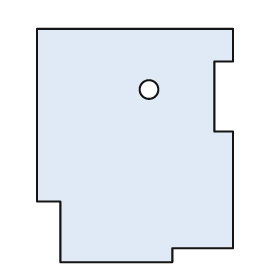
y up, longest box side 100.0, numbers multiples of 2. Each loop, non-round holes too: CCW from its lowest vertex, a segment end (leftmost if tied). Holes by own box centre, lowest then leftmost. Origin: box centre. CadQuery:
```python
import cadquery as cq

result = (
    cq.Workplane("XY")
    .moveTo(-32.0, -50.0)
    .lineTo(16.0, -50.0)
    .lineTo(16.0, -44.0)
    .lineTo(42.0, -44.0)
    .lineTo(42.0, 6.0)
    .lineTo(34.0, 6.0)
    .lineTo(34.0, 36.0)
    .lineTo(42.0, 36.0)
    .lineTo(42.0, 50.0)
    .lineTo(-42.0, 50.0)
    .lineTo(-42.0, -24.0)
    .lineTo(-32.0, -24.0)
    .close()
    .moveTo(6.0, 24.0)
    .circle(4.0)
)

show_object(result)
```